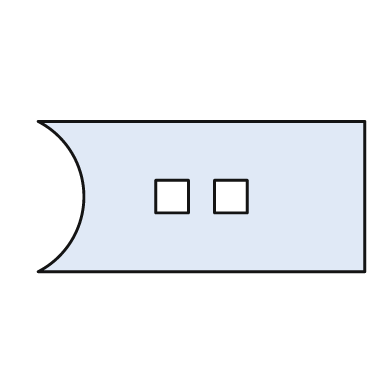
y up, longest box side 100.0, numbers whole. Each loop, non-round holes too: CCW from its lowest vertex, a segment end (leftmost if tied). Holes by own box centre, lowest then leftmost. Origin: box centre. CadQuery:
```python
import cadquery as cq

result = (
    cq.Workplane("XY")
    .moveTo(-50.0, -23.0)
    .lineTo(50.0, -23.0)
    .lineTo(50.0, 23.0)
    .lineTo(-50.0, 23.0)
    .threePointArc((-36.0, 0.0), (-50.0, -23.0))
    .close()
    .moveTo(-14.0, -5.0)
    .lineTo(-4.0, -5.0)
    .lineTo(-4.0, 5.0)
    .lineTo(-14.0, 5.0)
    .close()
    .moveTo(4.0, -5.0)
    .lineTo(14.0, -5.0)
    .lineTo(14.0, 5.0)
    .lineTo(4.0, 5.0)
    .close()
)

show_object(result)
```